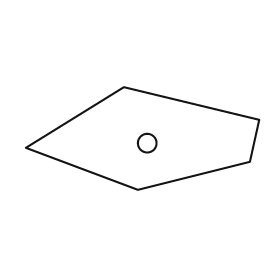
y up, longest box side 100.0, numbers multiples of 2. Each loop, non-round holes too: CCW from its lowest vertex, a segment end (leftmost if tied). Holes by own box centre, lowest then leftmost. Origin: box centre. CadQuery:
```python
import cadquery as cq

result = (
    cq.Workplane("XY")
    .moveTo(-2.0, -22.0)
    .lineTo(46.0, -10.0)
    .lineTo(50.0, 8.0)
    .lineTo(-8.0, 22.0)
    .lineTo(-50.0, -4.0)
    .close()
    .moveTo(2.0, -2.0)
    .circle(4.0)
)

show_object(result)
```